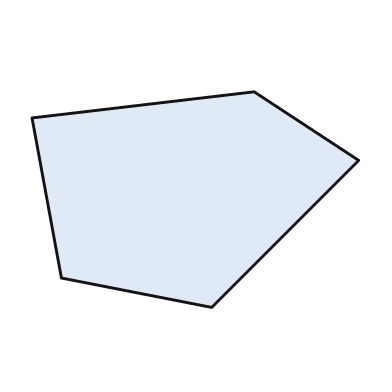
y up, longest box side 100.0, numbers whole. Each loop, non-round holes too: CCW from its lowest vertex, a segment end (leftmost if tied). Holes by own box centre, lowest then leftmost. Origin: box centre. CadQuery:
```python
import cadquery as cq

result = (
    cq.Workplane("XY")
    .moveTo(5.0, -33.0)
    .lineTo(50.0, 12.0)
    .lineTo(18.0, 33.0)
    .lineTo(-50.0, 25.0)
    .lineTo(-41.0, -24.0)
    .close()
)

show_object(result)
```